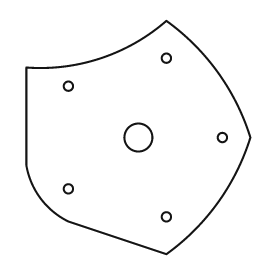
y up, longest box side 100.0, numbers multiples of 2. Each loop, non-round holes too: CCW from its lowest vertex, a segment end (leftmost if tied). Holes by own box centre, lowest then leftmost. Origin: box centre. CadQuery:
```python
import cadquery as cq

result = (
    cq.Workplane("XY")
    .moveTo(12.0, -50.0)
    .threePointArc((34.0, -28.0), (48.0, 0.0))
    .threePointArc((34.0, 28.0), (12.0, 50.0))
    .threePointArc((-16.0, 34.0), (-48.0, 30.0))
    .lineTo(-48.0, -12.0)
    .threePointArc((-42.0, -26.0), (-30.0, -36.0))
    .close()
    .moveTo(12.0, -34.0)
    .circle(2.0)
    .moveTo(-30.0, -22.0)
    .circle(2.0)
    .moveTo(0.0, 0.0)
    .circle(6.0)
    .moveTo(36.0, 0.0)
    .circle(2.0)
    .moveTo(-30.0, 22.0)
    .circle(2.0)
    .moveTo(12.0, 34.0)
    .circle(2.0)
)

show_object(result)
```